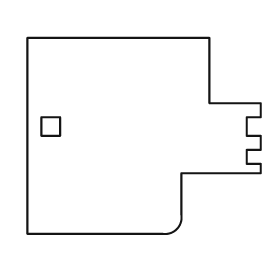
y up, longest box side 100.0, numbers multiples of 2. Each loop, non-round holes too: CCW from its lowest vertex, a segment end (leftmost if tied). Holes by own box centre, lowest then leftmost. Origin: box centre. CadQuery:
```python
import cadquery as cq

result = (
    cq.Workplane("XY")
    .moveTo(-50.0, -42.0)
    .lineTo(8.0, -42.0)
    .threePointArc((14.0, -40.0), (16.0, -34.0))
    .lineTo(16.0, -16.0)
    .lineTo(50.0, -16.0)
    .lineTo(50.0, -12.0)
    .lineTo(44.0, -12.0)
    .lineTo(44.0, -6.0)
    .lineTo(50.0, -6.0)
    .lineTo(50.0, 0.0)
    .lineTo(44.0, 0.0)
    .lineTo(44.0, 8.0)
    .lineTo(50.0, 8.0)
    .lineTo(50.0, 14.0)
    .lineTo(28.0, 14.0)
    .lineTo(28.0, 42.0)
    .lineTo(-50.0, 42.0)
    .close()
    .moveTo(-44.0, 0.0)
    .lineTo(-36.0, 0.0)
    .lineTo(-36.0, 8.0)
    .lineTo(-44.0, 8.0)
    .close()
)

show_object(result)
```